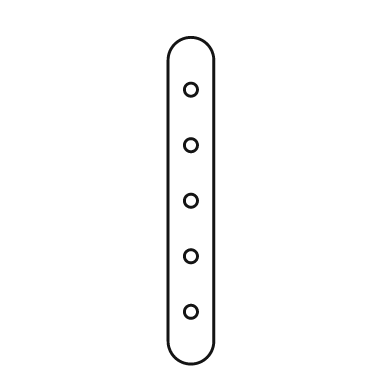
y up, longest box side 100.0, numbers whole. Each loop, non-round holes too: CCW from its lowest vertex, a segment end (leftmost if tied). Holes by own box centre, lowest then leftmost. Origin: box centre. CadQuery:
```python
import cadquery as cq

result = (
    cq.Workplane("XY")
    .moveTo(-7.0, -43.0)
    .threePointArc((0.0, -50.0), (7.0, -43.0))
    .lineTo(7.0, 43.0)
    .threePointArc((0.0, 50.0), (-7.0, 43.0))
    .close()
    .moveTo(0.0, -34.0)
    .circle(2.0)
    .moveTo(0.0, -17.0)
    .circle(2.0)
    .moveTo(0.0, 0.0)
    .circle(2.0)
    .moveTo(0.0, 17.0)
    .circle(2.0)
    .moveTo(0.0, 34.0)
    .circle(2.0)
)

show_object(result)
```